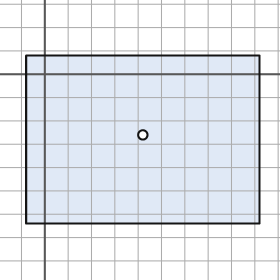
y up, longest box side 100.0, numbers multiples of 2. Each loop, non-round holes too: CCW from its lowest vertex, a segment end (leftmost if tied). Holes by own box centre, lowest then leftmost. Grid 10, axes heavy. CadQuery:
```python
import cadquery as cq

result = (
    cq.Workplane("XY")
    .moveTo(-8.0, -64.0)
    .lineTo(92.0, -64.0)
    .lineTo(92.0, 8.0)
    .lineTo(-8.0, 8.0)
    .close()
    .moveTo(42.0, -26.0)
    .circle(2.0)
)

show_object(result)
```